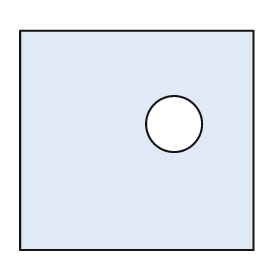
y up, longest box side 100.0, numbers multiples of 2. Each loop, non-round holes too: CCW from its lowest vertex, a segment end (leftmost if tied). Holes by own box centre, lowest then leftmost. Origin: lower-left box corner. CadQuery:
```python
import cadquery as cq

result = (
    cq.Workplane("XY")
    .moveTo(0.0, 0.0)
    .lineTo(100.0, 0.0)
    .lineTo(100.0, 94.0)
    .lineTo(0.0, 94.0)
    .close()
    .moveTo(66.0, 54.0)
    .circle(12.0)
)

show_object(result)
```